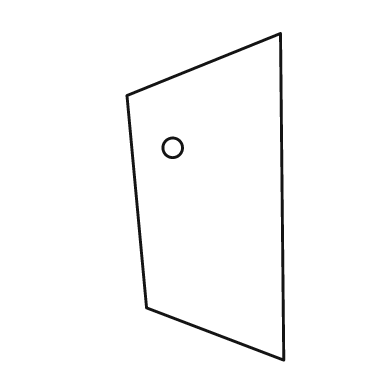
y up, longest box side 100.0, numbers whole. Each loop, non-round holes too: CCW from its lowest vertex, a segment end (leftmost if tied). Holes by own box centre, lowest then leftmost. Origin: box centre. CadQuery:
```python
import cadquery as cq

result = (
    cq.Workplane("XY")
    .moveTo(24.0, -50.0)
    .lineTo(23.0, 50.0)
    .lineTo(-24.0, 31.0)
    .lineTo(-18.0, -34.0)
    .close()
    .moveTo(-10.0, 15.0)
    .circle(3.0)
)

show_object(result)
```